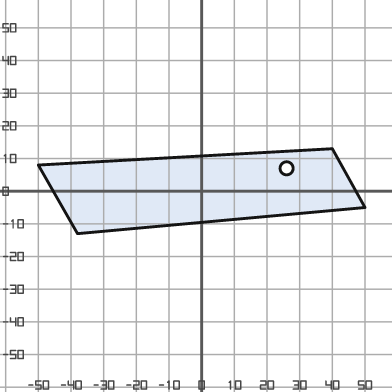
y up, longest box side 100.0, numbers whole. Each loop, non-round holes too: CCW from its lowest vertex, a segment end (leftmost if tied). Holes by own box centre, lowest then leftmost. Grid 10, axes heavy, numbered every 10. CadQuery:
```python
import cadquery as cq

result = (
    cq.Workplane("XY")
    .moveTo(-38.0, -13.0)
    .lineTo(50.0, -5.0)
    .lineTo(40.0, 13.0)
    .lineTo(-50.0, 8.0)
    .close()
    .moveTo(26.0, 7.0)
    .circle(2.0)
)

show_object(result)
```